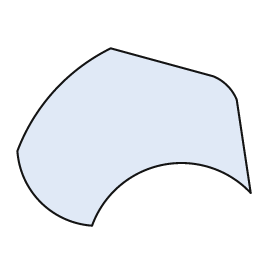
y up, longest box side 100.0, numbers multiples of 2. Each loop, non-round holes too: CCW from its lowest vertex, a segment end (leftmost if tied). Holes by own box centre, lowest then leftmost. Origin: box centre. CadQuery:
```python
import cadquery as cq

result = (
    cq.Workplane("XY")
    .moveTo(-18.0, -38.0)
    .threePointArc((12.0, -12.0), (50.0, -24.0))
    .lineTo(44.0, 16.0)
    .threePointArc((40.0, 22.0), (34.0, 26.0))
    .lineTo(-10.0, 38.0)
    .threePointArc((-34.0, 20.0), (-50.0, -6.0))
    .threePointArc((-40.0, -28.0), (-18.0, -38.0))
    .close()
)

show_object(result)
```